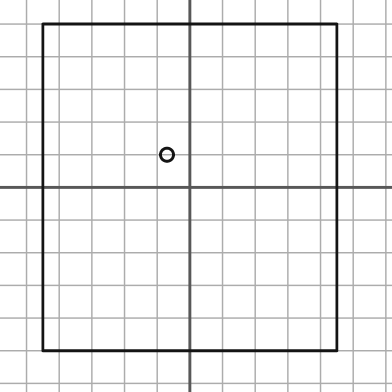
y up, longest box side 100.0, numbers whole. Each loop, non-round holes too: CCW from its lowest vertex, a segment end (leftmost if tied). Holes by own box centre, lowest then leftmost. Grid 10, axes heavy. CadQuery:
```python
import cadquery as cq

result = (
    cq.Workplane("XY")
    .moveTo(-45.0, -50.0)
    .lineTo(45.0, -50.0)
    .lineTo(45.0, 50.0)
    .lineTo(-45.0, 50.0)
    .close()
    .moveTo(-7.0, 10.0)
    .circle(2.0)
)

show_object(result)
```